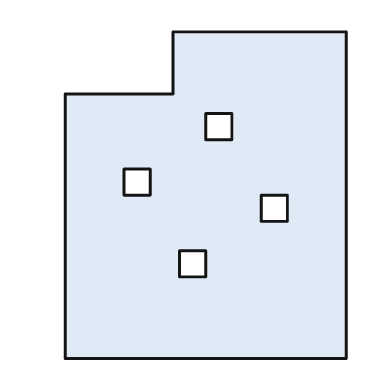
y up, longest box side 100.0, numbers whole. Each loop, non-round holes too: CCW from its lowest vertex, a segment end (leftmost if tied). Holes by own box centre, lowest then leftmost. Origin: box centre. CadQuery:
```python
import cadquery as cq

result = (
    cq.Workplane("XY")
    .moveTo(-43.0, -50.0)
    .lineTo(43.0, -50.0)
    .lineTo(43.0, 50.0)
    .lineTo(-10.0, 50.0)
    .lineTo(-10.0, 31.0)
    .lineTo(-43.0, 31.0)
    .close()
    .moveTo(-8.0, -25.0)
    .lineTo(0.0, -25.0)
    .lineTo(0.0, -17.0)
    .lineTo(-8.0, -17.0)
    .close()
    .moveTo(17.0, -8.0)
    .lineTo(25.0, -8.0)
    .lineTo(25.0, 0.0)
    .lineTo(17.0, 0.0)
    .close()
    .moveTo(-25.0, 0.0)
    .lineTo(-17.0, 0.0)
    .lineTo(-17.0, 8.0)
    .lineTo(-25.0, 8.0)
    .close()
    .moveTo(0.0, 17.0)
    .lineTo(8.0, 17.0)
    .lineTo(8.0, 25.0)
    .lineTo(0.0, 25.0)
    .close()
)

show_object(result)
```